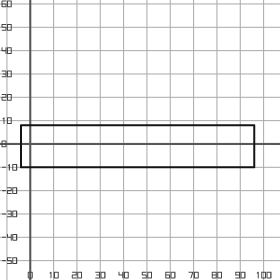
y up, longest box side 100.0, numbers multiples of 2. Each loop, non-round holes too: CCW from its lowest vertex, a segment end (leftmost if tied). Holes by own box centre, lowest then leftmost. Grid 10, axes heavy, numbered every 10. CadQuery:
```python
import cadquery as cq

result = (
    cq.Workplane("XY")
    .moveTo(-4.0, -10.0)
    .lineTo(96.0, -10.0)
    .lineTo(96.0, 8.0)
    .lineTo(-4.0, 8.0)
    .close()
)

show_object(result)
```